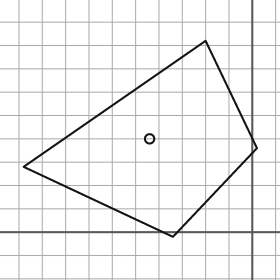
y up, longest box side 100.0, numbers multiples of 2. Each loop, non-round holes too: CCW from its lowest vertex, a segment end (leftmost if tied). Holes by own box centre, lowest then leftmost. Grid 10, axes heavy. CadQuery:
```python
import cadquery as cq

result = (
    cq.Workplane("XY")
    .moveTo(-34.0, -2.0)
    .lineTo(2.0, 36.0)
    .lineTo(-20.0, 82.0)
    .lineTo(-98.0, 28.0)
    .close()
    .moveTo(-44.0, 40.0)
    .circle(2.0)
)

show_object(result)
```